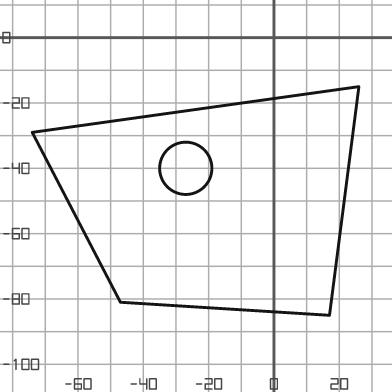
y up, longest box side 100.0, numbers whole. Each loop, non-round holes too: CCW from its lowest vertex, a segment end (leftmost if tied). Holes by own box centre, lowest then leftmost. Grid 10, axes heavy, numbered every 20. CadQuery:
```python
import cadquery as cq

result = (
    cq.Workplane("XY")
    .moveTo(17.0, -85.0)
    .lineTo(26.0, -15.0)
    .lineTo(-74.0, -29.0)
    .lineTo(-47.0, -81.0)
    .close()
    .moveTo(-27.0, -40.0)
    .circle(8.0)
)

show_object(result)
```